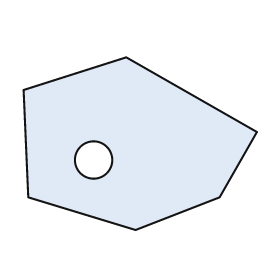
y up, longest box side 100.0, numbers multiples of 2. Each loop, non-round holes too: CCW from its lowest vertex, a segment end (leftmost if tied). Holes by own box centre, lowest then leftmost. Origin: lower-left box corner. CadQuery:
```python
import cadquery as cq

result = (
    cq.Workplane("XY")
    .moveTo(48.0, 0.0)
    .lineTo(84.0, 14.0)
    .lineTo(100.0, 42.0)
    .lineTo(44.0, 74.0)
    .lineTo(0.0, 60.0)
    .lineTo(2.0, 14.0)
    .close()
    .moveTo(30.0, 30.0)
    .circle(8.0)
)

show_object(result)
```